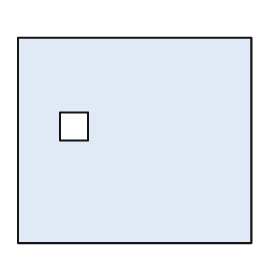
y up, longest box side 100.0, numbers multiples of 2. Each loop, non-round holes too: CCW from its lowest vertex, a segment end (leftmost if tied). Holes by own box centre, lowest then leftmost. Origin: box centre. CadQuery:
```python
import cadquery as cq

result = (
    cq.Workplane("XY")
    .moveTo(-50.0, -44.0)
    .lineTo(50.0, -44.0)
    .lineTo(50.0, 44.0)
    .lineTo(-50.0, 44.0)
    .close()
    .moveTo(-32.0, 0.0)
    .lineTo(-20.0, 0.0)
    .lineTo(-20.0, 12.0)
    .lineTo(-32.0, 12.0)
    .close()
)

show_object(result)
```